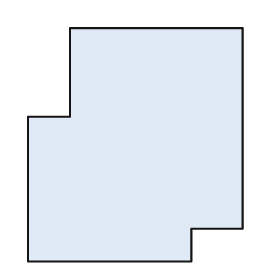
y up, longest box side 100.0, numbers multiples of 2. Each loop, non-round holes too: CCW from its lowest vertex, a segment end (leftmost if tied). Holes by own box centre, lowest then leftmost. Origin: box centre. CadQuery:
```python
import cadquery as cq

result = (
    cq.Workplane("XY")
    .moveTo(-46.0, -50.0)
    .lineTo(24.0, -50.0)
    .lineTo(24.0, -36.0)
    .lineTo(46.0, -36.0)
    .lineTo(46.0, 50.0)
    .lineTo(-28.0, 50.0)
    .lineTo(-28.0, 12.0)
    .lineTo(-46.0, 12.0)
    .close()
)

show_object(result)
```